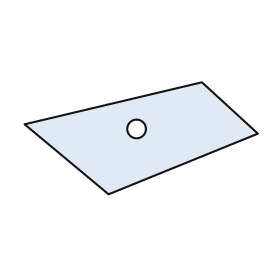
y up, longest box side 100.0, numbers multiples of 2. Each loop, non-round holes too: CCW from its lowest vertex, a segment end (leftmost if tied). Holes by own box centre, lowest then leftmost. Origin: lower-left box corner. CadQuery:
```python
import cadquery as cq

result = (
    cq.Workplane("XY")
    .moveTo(36.0, 0.0)
    .lineTo(100.0, 26.0)
    .lineTo(76.0, 48.0)
    .lineTo(0.0, 30.0)
    .close()
    .moveTo(48.0, 28.0)
    .circle(4.0)
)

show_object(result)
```